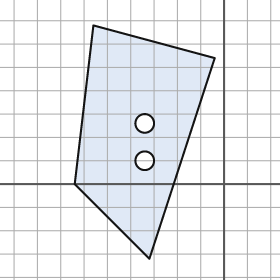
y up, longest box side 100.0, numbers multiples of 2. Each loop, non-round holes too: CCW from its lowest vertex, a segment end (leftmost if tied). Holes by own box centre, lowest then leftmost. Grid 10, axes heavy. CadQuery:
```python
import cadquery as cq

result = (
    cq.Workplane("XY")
    .moveTo(-32.0, -32.0)
    .lineTo(-4.0, 54.0)
    .lineTo(-56.0, 68.0)
    .lineTo(-64.0, 0.0)
    .close()
    .moveTo(-34.0, 10.0)
    .circle(4.0)
    .moveTo(-34.0, 26.0)
    .circle(4.0)
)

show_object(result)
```